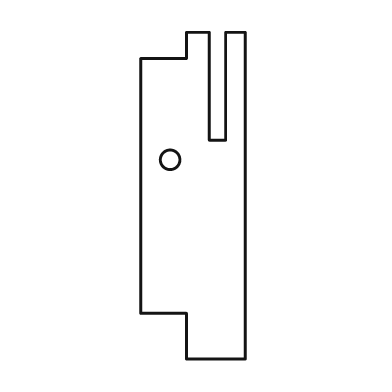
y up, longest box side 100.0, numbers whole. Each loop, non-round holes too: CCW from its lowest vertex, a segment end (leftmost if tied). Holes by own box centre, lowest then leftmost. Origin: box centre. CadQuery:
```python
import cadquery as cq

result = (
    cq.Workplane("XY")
    .moveTo(-2.0, -50.0)
    .lineTo(16.0, -50.0)
    .lineTo(16.0, 50.0)
    .lineTo(10.0, 50.0)
    .lineTo(10.0, 17.0)
    .lineTo(5.0, 17.0)
    .lineTo(5.0, 50.0)
    .lineTo(-2.0, 50.0)
    .lineTo(-2.0, 42.0)
    .lineTo(-16.0, 42.0)
    .lineTo(-16.0, -36.0)
    .lineTo(-2.0, -36.0)
    .close()
    .moveTo(-7.0, 11.0)
    .circle(3.0)
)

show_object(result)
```